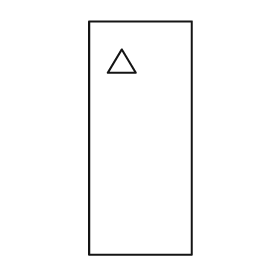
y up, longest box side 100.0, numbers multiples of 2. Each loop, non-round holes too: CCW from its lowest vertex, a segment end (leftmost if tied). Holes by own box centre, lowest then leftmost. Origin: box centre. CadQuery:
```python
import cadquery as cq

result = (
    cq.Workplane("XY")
    .moveTo(-22.0, -50.0)
    .lineTo(22.0, -50.0)
    .lineTo(22.0, 50.0)
    .lineTo(-22.0, 50.0)
    .close()
    .moveTo(-14.0, 28.0)
    .lineTo(-2.0, 28.0)
    .lineTo(-8.0, 38.0)
    .close()
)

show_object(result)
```